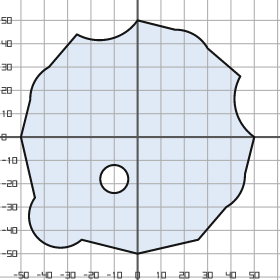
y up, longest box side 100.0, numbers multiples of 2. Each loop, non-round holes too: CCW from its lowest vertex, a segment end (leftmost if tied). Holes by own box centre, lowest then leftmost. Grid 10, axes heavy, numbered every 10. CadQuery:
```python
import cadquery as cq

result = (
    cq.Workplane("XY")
    .moveTo(0.0, -50.0)
    .lineTo(26.0, -44.0)
    .lineTo(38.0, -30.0)
    .threePointArc((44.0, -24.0), (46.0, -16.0))
    .lineTo(50.0, 0.0)
    .threePointArc((42.0, 12.0), (44.0, 26.0))
    .lineTo(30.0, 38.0)
    .threePointArc((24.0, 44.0), (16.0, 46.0))
    .lineTo(0.0, 50.0)
    .threePointArc((-12.0, 42.0), (-26.0, 44.0))
    .lineTo(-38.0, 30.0)
    .threePointArc((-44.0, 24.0), (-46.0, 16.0))
    .lineTo(-50.0, 0.0)
    .lineTo(-44.0, -26.0)
    .threePointArc((-42.0, -44.0), (-24.0, -44.0))
    .close()
    .moveTo(-10.0, -18.0)
    .circle(6.0)
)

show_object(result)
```